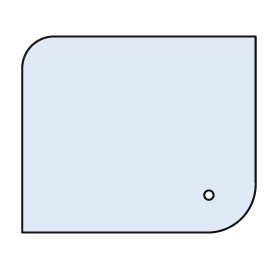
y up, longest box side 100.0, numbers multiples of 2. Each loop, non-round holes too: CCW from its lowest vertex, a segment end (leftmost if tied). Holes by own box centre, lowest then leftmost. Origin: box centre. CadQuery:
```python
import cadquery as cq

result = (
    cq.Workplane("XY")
    .moveTo(-50.0, -42.0)
    .lineTo(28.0, -42.0)
    .threePointArc((44.0, -36.0), (50.0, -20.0))
    .lineTo(50.0, 42.0)
    .lineTo(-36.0, 42.0)
    .threePointArc((-46.0, 38.0), (-50.0, 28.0))
    .close()
    .moveTo(30.0, -26.0)
    .circle(2.0)
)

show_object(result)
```